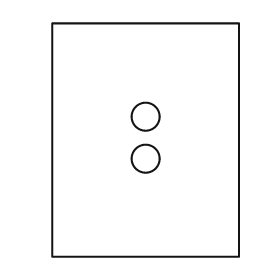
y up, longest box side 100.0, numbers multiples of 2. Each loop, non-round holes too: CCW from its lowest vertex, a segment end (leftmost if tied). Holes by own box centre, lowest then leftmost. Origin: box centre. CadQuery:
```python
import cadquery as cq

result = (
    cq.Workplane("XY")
    .moveTo(-40.0, -50.0)
    .lineTo(40.0, -50.0)
    .lineTo(40.0, 50.0)
    .lineTo(-40.0, 50.0)
    .close()
    .moveTo(0.0, -8.0)
    .circle(6.0)
    .moveTo(0.0, 10.0)
    .circle(6.0)
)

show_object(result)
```